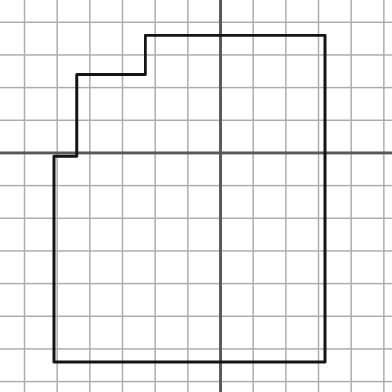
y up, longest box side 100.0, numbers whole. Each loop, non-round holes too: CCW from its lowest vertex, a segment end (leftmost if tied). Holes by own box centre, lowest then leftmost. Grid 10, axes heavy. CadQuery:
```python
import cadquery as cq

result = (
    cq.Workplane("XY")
    .moveTo(-51.0, -64.0)
    .lineTo(32.0, -64.0)
    .lineTo(32.0, 36.0)
    .lineTo(-23.0, 36.0)
    .lineTo(-23.0, 24.0)
    .lineTo(-44.0, 24.0)
    .lineTo(-44.0, -1.0)
    .lineTo(-51.0, -1.0)
    .close()
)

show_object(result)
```